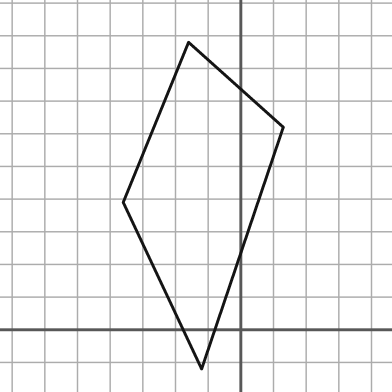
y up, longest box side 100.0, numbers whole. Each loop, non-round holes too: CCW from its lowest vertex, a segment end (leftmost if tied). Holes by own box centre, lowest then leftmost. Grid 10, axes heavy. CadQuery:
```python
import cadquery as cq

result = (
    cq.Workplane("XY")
    .moveTo(-12.0, -12.0)
    .lineTo(13.0, 62.0)
    .lineTo(-16.0, 88.0)
    .lineTo(-36.0, 39.0)
    .close()
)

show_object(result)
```